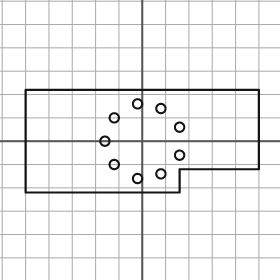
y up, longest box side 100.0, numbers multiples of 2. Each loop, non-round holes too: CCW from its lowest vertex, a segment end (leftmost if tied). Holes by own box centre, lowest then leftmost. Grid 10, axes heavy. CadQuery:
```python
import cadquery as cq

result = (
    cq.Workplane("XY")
    .moveTo(-50.0, -22.0)
    .lineTo(16.0, -22.0)
    .lineTo(16.0, -12.0)
    .lineTo(50.0, -12.0)
    .lineTo(50.0, 22.0)
    .lineTo(-50.0, 22.0)
    .close()
    .moveTo(-2.0, -16.0)
    .circle(2.0)
    .moveTo(8.0, -14.0)
    .circle(2.0)
    .moveTo(-12.0, -10.0)
    .circle(2.0)
    .moveTo(16.0, -6.0)
    .circle(2.0)
    .moveTo(-16.0, 0.0)
    .circle(2.0)
    .moveTo(16.0, 6.0)
    .circle(2.0)
    .moveTo(-12.0, 10.0)
    .circle(2.0)
    .moveTo(8.0, 14.0)
    .circle(2.0)
    .moveTo(-2.0, 16.0)
    .circle(2.0)
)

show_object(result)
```